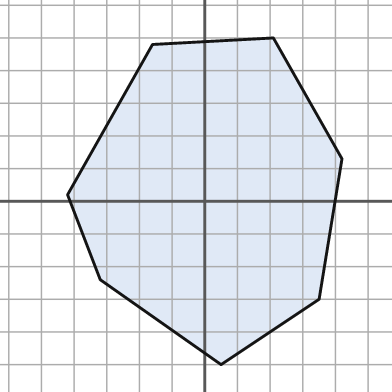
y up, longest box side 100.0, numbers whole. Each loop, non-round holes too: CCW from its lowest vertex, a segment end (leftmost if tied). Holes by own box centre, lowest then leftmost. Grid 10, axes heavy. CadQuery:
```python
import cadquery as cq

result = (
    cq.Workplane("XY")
    .moveTo(5.0, -50.0)
    .lineTo(35.0, -30.0)
    .lineTo(42.0, 13.0)
    .lineTo(21.0, 50.0)
    .lineTo(-16.0, 48.0)
    .lineTo(-42.0, 2.0)
    .lineTo(-32.0, -24.0)
    .close()
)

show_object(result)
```